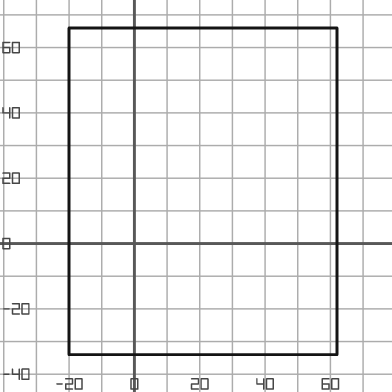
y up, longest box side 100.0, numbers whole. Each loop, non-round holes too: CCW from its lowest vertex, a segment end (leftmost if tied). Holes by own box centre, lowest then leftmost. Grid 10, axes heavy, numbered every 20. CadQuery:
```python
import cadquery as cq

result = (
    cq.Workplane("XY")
    .moveTo(-20.0, -34.0)
    .lineTo(62.0, -34.0)
    .lineTo(62.0, 66.0)
    .lineTo(-20.0, 66.0)
    .close()
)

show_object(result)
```